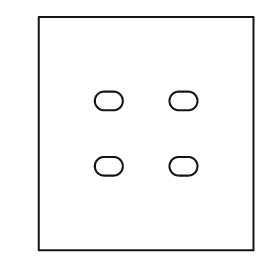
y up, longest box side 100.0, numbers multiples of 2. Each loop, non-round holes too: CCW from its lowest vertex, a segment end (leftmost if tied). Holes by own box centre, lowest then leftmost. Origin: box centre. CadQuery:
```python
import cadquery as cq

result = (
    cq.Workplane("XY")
    .moveTo(-46.0, -50.0)
    .lineTo(46.0, -50.0)
    .lineTo(46.0, 50.0)
    .lineTo(-46.0, 50.0)
    .close()
    .moveTo(-18.0, -18.0)
    .lineTo(-14.0, -18.0)
    .threePointArc((-10.0, -14.0), (-14.0, -10.0))
    .lineTo(-18.0, -10.0)
    .threePointArc((-22.0, -14.0), (-18.0, -18.0))
    .close()
    .moveTo(14.0, -18.0)
    .lineTo(18.0, -18.0)
    .threePointArc((22.0, -14.0), (18.0, -10.0))
    .lineTo(14.0, -10.0)
    .threePointArc((10.0, -14.0), (14.0, -18.0))
    .close()
    .moveTo(-18.0, 10.0)
    .lineTo(-14.0, 10.0)
    .threePointArc((-10.0, 14.0), (-14.0, 18.0))
    .lineTo(-18.0, 18.0)
    .threePointArc((-22.0, 14.0), (-18.0, 10.0))
    .close()
    .moveTo(14.0, 10.0)
    .lineTo(18.0, 10.0)
    .threePointArc((22.0, 14.0), (18.0, 18.0))
    .lineTo(14.0, 18.0)
    .threePointArc((10.0, 14.0), (14.0, 10.0))
    .close()
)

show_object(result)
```